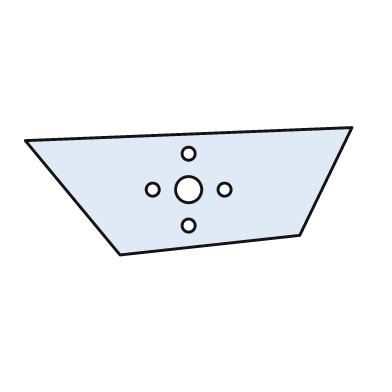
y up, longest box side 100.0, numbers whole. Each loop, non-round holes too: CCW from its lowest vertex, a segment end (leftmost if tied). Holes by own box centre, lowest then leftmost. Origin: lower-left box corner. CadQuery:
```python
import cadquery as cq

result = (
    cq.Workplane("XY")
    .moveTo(29.0, 0.0)
    .lineTo(84.0, 6.0)
    .lineTo(100.0, 39.0)
    .lineTo(0.0, 35.0)
    .close()
    .moveTo(50.0, 9.0)
    .circle(2.0)
    .moveTo(39.0, 20.0)
    .circle(2.0)
    .moveTo(50.0, 20.0)
    .circle(4.0)
    .moveTo(61.0, 20.0)
    .circle(2.0)
    .moveTo(50.0, 31.0)
    .circle(2.0)
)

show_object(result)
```